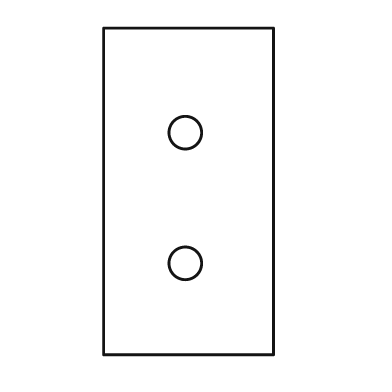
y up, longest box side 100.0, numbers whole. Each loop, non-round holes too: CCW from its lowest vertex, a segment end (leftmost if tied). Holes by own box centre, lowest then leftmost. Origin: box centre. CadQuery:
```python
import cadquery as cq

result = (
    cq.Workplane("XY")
    .moveTo(-26.0, -50.0)
    .lineTo(26.0, -50.0)
    .lineTo(26.0, 50.0)
    .lineTo(-26.0, 50.0)
    .close()
    .moveTo(-1.0, -22.0)
    .circle(5.0)
    .moveTo(-1.0, 18.0)
    .circle(5.0)
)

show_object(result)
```